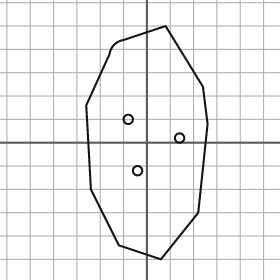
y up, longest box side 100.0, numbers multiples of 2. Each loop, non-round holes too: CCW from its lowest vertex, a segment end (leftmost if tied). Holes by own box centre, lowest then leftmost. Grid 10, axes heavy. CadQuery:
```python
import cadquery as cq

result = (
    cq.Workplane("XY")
    .moveTo(6.0, -50.0)
    .lineTo(22.0, -30.0)
    .lineTo(26.0, 8.0)
    .lineTo(24.0, 24.0)
    .lineTo(8.0, 50.0)
    .lineTo(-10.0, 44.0)
    .threePointArc((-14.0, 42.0), (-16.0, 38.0))
    .lineTo(-26.0, 16.0)
    .lineTo(-24.0, -20.0)
    .lineTo(-12.0, -44.0)
    .close()
    .moveTo(-4.0, -12.0)
    .circle(2.0)
    .moveTo(14.0, 2.0)
    .circle(2.0)
    .moveTo(-8.0, 10.0)
    .circle(2.0)
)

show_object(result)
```